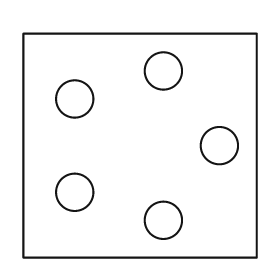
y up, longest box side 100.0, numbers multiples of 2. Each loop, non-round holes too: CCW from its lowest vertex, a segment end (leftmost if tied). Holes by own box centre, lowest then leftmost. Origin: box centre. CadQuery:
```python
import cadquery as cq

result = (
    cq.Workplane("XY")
    .moveTo(-50.0, -48.0)
    .lineTo(50.0, -48.0)
    .lineTo(50.0, 48.0)
    .lineTo(-50.0, 48.0)
    .close()
    .moveTo(10.0, -32.0)
    .circle(8.0)
    .moveTo(-28.0, -20.0)
    .circle(8.0)
    .moveTo(34.0, 0.0)
    .circle(8.0)
    .moveTo(-28.0, 20.0)
    .circle(8.0)
    .moveTo(10.0, 32.0)
    .circle(8.0)
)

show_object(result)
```